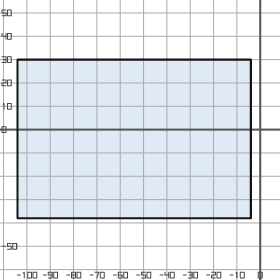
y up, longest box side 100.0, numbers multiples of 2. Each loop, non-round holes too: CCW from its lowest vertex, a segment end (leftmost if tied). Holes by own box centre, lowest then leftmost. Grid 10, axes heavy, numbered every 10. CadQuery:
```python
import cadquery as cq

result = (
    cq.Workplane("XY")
    .moveTo(-104.0, -38.0)
    .lineTo(-4.0, -38.0)
    .lineTo(-4.0, 30.0)
    .lineTo(-104.0, 30.0)
    .close()
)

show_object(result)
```